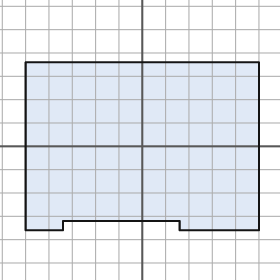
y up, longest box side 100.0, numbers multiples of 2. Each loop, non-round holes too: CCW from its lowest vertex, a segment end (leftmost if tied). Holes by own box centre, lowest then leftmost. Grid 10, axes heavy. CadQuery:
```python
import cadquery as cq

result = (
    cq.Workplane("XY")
    .moveTo(-50.0, -36.0)
    .lineTo(-34.0, -36.0)
    .lineTo(-34.0, -32.0)
    .lineTo(16.0, -32.0)
    .lineTo(16.0, -36.0)
    .lineTo(50.0, -36.0)
    .lineTo(50.0, 36.0)
    .lineTo(-50.0, 36.0)
    .close()
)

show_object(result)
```